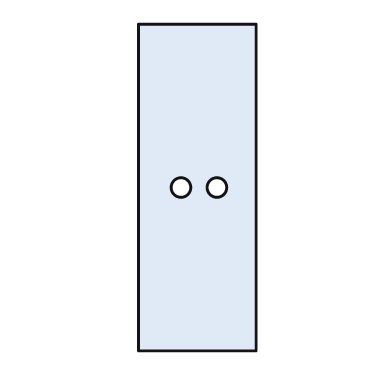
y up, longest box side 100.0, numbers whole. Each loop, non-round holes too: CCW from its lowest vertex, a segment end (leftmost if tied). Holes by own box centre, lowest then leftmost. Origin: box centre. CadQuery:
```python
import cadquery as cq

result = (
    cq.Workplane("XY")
    .moveTo(-18.0, -50.0)
    .lineTo(18.0, -50.0)
    .lineTo(18.0, 50.0)
    .lineTo(-18.0, 50.0)
    .close()
    .moveTo(-5.0, 0.0)
    .circle(3.0)
    .moveTo(6.0, 0.0)
    .circle(3.0)
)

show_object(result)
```